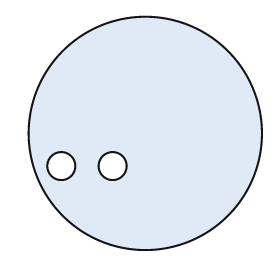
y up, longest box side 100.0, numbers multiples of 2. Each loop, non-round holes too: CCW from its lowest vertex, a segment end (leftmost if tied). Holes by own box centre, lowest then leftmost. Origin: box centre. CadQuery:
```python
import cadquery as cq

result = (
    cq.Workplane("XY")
    .moveTo(0.0, 0.0)
    .circle(50.0)
    .moveTo(-36.0, -14.0)
    .circle(6.0)
    .moveTo(-14.0, -14.0)
    .circle(6.0)
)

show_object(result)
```